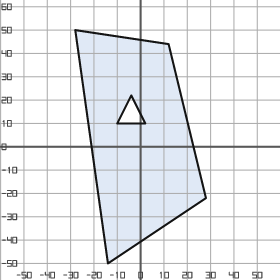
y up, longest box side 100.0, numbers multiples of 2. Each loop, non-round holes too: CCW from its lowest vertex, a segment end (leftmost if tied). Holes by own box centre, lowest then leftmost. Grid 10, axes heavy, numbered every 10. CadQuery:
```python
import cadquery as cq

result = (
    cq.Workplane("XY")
    .moveTo(-14.0, -50.0)
    .lineTo(28.0, -22.0)
    .lineTo(12.0, 44.0)
    .lineTo(-28.0, 50.0)
    .close()
    .moveTo(-10.0, 10.0)
    .lineTo(2.0, 10.0)
    .lineTo(-4.0, 22.0)
    .close()
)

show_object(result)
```